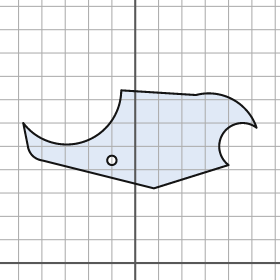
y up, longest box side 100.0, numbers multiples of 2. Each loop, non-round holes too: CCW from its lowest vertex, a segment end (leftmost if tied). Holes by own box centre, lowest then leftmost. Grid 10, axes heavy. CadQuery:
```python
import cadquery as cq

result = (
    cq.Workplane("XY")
    .moveTo(8.0, 32.0)
    .lineTo(40.0, 42.0)
    .threePointArc((38.0, 56.0), (52.0, 58.0))
    .threePointArc((42.0, 70.0), (26.0, 72.0))
    .lineTo(-6.0, 74.0)
    .threePointArc((-22.0, 52.0), (-48.0, 60.0))
    .lineTo(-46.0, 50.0)
    .threePointArc((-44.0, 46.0), (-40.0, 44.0))
    .close()
    .moveTo(-10.0, 44.0)
    .circle(2.0)
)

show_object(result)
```